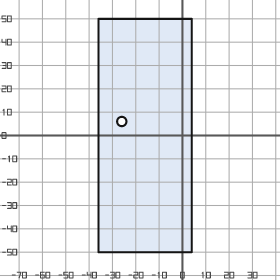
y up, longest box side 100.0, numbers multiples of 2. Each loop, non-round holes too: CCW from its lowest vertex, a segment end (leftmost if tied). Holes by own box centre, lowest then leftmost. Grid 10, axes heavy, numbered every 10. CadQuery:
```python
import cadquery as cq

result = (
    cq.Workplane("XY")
    .moveTo(-36.0, -50.0)
    .lineTo(4.0, -50.0)
    .lineTo(4.0, 50.0)
    .lineTo(-36.0, 50.0)
    .close()
    .moveTo(-26.0, 6.0)
    .circle(2.0)
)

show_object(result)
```